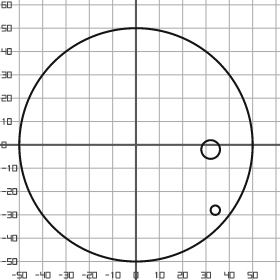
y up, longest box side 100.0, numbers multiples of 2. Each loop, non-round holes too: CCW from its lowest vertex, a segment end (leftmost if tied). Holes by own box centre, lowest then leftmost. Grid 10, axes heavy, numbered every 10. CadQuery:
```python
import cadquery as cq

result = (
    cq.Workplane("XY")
    .moveTo(0.0, 0.0)
    .circle(50.0)
    .moveTo(34.0, -28.0)
    .circle(2.0)
    .moveTo(32.0, -2.0)
    .circle(4.0)
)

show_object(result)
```